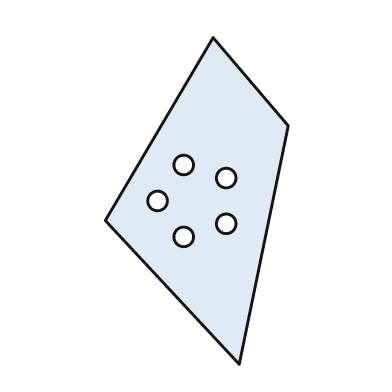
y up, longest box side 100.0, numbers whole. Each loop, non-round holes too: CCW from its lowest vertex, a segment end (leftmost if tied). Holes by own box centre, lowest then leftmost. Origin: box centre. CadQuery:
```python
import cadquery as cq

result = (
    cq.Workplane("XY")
    .moveTo(13.0, -50.0)
    .lineTo(28.0, 23.0)
    .lineTo(5.0, 50.0)
    .lineTo(-28.0, -6.0)
    .close()
    .moveTo(-4.0, -11.0)
    .circle(3.0)
    .moveTo(9.0, -7.0)
    .circle(3.0)
    .moveTo(-12.0, 0.0)
    .circle(3.0)
    .moveTo(9.0, 7.0)
    .circle(3.0)
    .moveTo(-4.0, 11.0)
    .circle(3.0)
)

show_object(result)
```